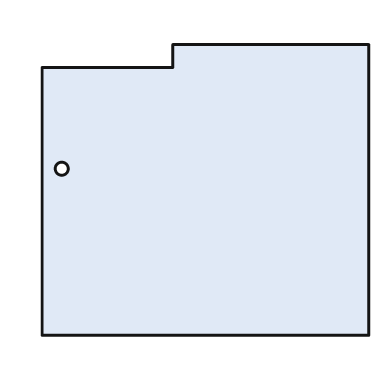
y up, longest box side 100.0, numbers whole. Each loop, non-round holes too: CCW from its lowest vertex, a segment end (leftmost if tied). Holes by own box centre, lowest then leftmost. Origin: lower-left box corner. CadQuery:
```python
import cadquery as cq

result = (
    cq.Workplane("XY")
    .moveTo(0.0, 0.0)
    .lineTo(100.0, 0.0)
    .lineTo(100.0, 89.0)
    .lineTo(40.0, 89.0)
    .lineTo(40.0, 82.0)
    .lineTo(0.0, 82.0)
    .close()
    .moveTo(6.0, 51.0)
    .circle(2.0)
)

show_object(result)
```